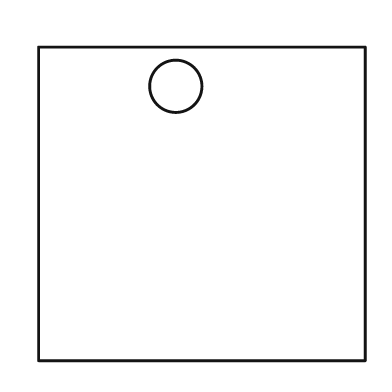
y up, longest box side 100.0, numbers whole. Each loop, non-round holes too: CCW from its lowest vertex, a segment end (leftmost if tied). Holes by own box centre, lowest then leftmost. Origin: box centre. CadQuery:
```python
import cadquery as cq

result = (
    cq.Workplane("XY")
    .moveTo(-50.0, -48.0)
    .lineTo(50.0, -48.0)
    .lineTo(50.0, 48.0)
    .lineTo(-50.0, 48.0)
    .close()
    .moveTo(-8.0, 36.0)
    .circle(8.0)
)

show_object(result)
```